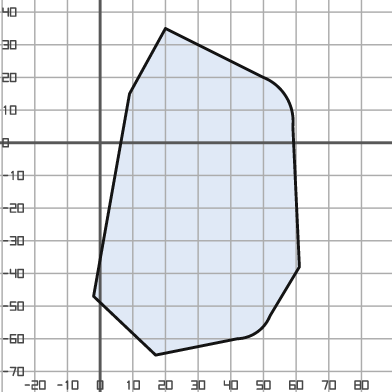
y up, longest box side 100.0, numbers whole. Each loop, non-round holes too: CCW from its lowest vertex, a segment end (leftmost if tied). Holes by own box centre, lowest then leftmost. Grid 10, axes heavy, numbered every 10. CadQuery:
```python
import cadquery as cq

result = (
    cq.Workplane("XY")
    .moveTo(17.0, -65.0)
    .lineTo(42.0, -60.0)
    .threePointArc((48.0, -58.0), (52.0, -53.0))
    .lineTo(61.0, -38.0)
    .lineTo(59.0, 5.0)
    .threePointArc((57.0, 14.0), (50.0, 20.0))
    .lineTo(20.0, 35.0)
    .lineTo(9.0, 15.0)
    .lineTo(-2.0, -47.0)
    .close()
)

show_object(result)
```